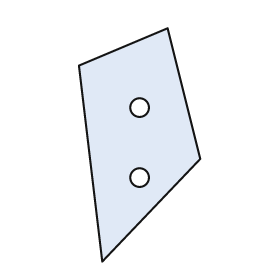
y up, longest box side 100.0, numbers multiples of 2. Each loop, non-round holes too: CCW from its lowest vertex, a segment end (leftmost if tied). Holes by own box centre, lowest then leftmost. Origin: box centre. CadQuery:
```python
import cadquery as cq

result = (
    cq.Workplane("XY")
    .moveTo(-16.0, -50.0)
    .lineTo(26.0, -6.0)
    .lineTo(12.0, 50.0)
    .lineTo(-26.0, 34.0)
    .close()
    .moveTo(0.0, -14.0)
    .circle(4.0)
    .moveTo(0.0, 16.0)
    .circle(4.0)
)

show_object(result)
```